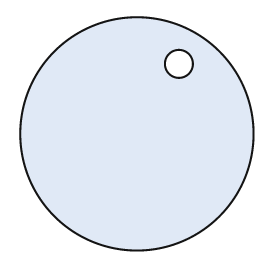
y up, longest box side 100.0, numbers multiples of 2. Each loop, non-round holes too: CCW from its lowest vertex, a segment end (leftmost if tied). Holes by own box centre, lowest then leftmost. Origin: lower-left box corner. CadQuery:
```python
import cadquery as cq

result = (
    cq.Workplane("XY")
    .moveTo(50.0, 50.0)
    .circle(50.0)
    .moveTo(68.0, 80.0)
    .circle(6.0)
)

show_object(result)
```